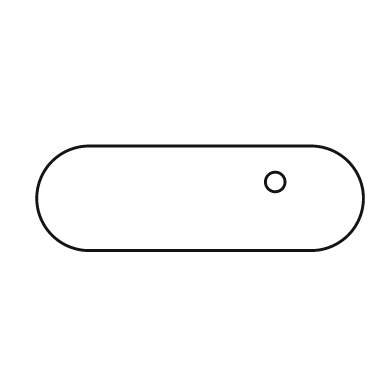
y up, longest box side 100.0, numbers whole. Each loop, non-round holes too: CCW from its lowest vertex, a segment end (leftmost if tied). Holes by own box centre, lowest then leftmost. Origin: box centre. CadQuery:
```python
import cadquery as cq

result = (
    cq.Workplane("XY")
    .moveTo(-34.0, -16.0)
    .lineTo(34.0, -16.0)
    .threePointArc((50.0, 0.0), (34.0, 16.0))
    .lineTo(-34.0, 16.0)
    .threePointArc((-50.0, 0.0), (-34.0, -16.0))
    .close()
    .moveTo(23.0, 5.0)
    .circle(3.0)
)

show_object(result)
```